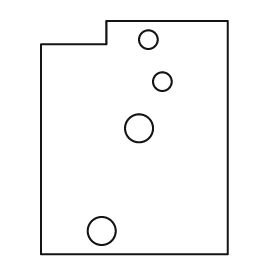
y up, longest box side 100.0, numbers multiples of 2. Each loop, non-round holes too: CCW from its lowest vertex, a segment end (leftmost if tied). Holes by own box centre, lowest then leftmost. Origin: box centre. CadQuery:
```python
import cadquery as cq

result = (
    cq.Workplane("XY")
    .moveTo(-40.0, -50.0)
    .lineTo(40.0, -50.0)
    .lineTo(40.0, 50.0)
    .lineTo(-12.0, 50.0)
    .lineTo(-12.0, 40.0)
    .lineTo(-40.0, 40.0)
    .close()
    .moveTo(-14.0, -40.0)
    .circle(6.0)
    .moveTo(2.0, 4.0)
    .circle(6.0)
    .moveTo(12.0, 24.0)
    .circle(4.0)
    .moveTo(6.0, 42.0)
    .circle(4.0)
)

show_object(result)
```